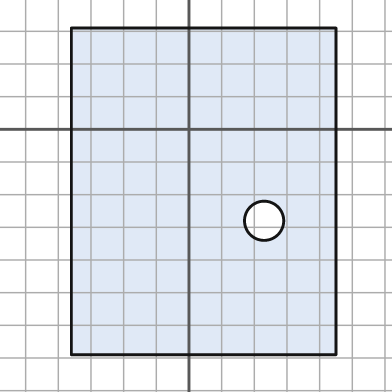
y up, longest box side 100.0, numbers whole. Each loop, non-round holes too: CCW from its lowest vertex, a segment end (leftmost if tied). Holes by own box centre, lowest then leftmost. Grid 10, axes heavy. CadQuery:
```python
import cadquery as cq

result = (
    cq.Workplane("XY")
    .moveTo(-36.0, -69.0)
    .lineTo(45.0, -69.0)
    .lineTo(45.0, 31.0)
    .lineTo(-36.0, 31.0)
    .close()
    .moveTo(23.0, -28.0)
    .circle(6.0)
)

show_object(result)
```